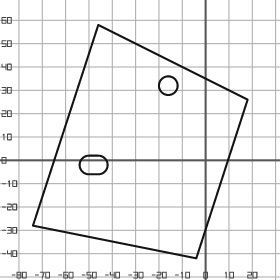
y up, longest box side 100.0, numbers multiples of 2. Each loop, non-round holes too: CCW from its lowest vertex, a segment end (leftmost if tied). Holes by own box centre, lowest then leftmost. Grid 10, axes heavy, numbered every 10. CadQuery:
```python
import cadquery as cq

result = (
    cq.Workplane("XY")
    .moveTo(-4.0, -42.0)
    .lineTo(18.0, 26.0)
    .lineTo(-46.0, 58.0)
    .lineTo(-74.0, -28.0)
    .close()
    .moveTo(-50.0, -6.0)
    .lineTo(-46.0, -6.0)
    .threePointArc((-42.0, -2.0), (-46.0, 2.0))
    .lineTo(-50.0, 2.0)
    .threePointArc((-54.0, -2.0), (-50.0, -6.0))
    .close()
    .moveTo(-16.0, 32.0)
    .circle(4.0)
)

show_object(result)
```